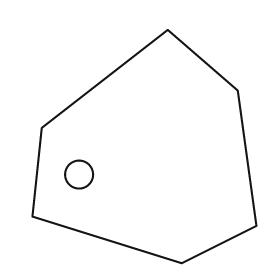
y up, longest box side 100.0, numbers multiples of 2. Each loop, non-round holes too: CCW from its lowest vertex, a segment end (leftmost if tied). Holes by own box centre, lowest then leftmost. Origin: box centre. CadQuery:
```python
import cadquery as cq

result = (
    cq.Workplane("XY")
    .moveTo(16.0, -50.0)
    .lineTo(48.0, -34.0)
    .lineTo(40.0, 24.0)
    .lineTo(10.0, 50.0)
    .lineTo(-44.0, 8.0)
    .lineTo(-48.0, -30.0)
    .close()
    .moveTo(-28.0, -12.0)
    .circle(6.0)
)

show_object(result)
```